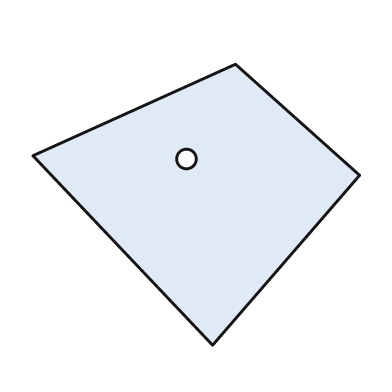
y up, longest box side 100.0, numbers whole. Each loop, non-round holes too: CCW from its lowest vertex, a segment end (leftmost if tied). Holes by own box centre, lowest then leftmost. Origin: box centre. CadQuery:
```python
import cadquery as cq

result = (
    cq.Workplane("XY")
    .moveTo(5.0, -43.0)
    .lineTo(50.0, 9.0)
    .lineTo(12.0, 43.0)
    .lineTo(-50.0, 15.0)
    .close()
    .moveTo(-3.0, 14.0)
    .circle(3.0)
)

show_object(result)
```